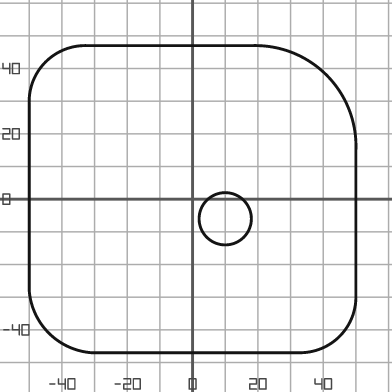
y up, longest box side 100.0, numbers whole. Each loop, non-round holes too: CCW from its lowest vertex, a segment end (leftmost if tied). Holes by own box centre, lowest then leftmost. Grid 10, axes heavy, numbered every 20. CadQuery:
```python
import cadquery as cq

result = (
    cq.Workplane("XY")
    .moveTo(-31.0, -47.0)
    .lineTo(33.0, -47.0)
    .threePointArc((45.0, -42.0), (50.0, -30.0))
    .lineTo(50.0, 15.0)
    .threePointArc((41.0, 38.0), (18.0, 47.0))
    .lineTo(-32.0, 47.0)
    .threePointArc((-45.0, 42.0), (-50.0, 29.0))
    .lineTo(-50.0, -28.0)
    .threePointArc((-44.0, -41.0), (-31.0, -47.0))
    .close()
    .moveTo(10.0, -6.0)
    .circle(8.0)
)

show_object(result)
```